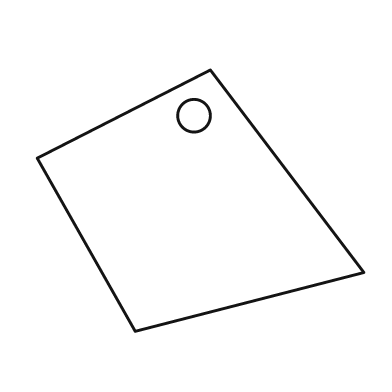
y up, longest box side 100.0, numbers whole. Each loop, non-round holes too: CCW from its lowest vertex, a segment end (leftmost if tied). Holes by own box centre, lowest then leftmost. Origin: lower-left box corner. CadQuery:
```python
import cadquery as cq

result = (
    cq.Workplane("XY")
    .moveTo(30.0, 0.0)
    .lineTo(100.0, 18.0)
    .lineTo(53.0, 80.0)
    .lineTo(0.0, 53.0)
    .close()
    .moveTo(48.0, 66.0)
    .circle(5.0)
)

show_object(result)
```